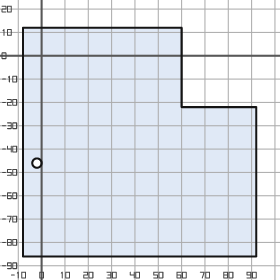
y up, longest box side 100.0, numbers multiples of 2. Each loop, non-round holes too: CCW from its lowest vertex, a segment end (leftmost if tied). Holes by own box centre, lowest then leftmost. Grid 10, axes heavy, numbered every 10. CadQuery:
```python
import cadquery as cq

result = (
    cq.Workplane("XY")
    .moveTo(-8.0, -86.0)
    .lineTo(92.0, -86.0)
    .lineTo(92.0, -22.0)
    .lineTo(60.0, -22.0)
    .lineTo(60.0, 12.0)
    .lineTo(-8.0, 12.0)
    .close()
    .moveTo(-2.0, -46.0)
    .circle(2.0)
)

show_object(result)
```